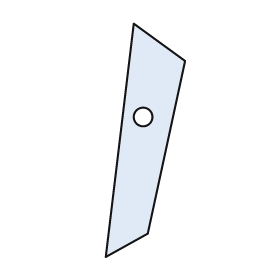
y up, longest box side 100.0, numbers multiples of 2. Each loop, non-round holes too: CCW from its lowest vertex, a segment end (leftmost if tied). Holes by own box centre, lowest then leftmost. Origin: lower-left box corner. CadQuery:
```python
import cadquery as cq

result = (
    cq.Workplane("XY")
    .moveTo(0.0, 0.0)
    .lineTo(18.0, 10.0)
    .lineTo(34.0, 84.0)
    .lineTo(12.0, 100.0)
    .close()
    .moveTo(16.0, 60.0)
    .circle(4.0)
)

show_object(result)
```